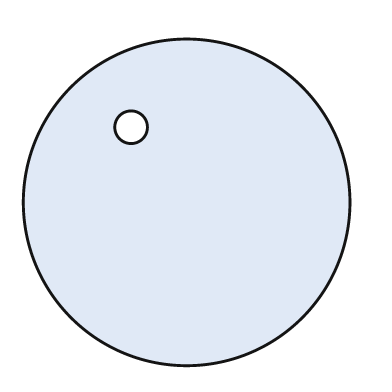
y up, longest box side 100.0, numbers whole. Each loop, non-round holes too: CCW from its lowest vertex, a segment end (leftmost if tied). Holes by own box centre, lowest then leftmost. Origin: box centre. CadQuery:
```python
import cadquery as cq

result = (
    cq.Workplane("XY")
    .moveTo(0.0, 0.0)
    .circle(50.0)
    .moveTo(-17.0, 23.0)
    .circle(5.0)
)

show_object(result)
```